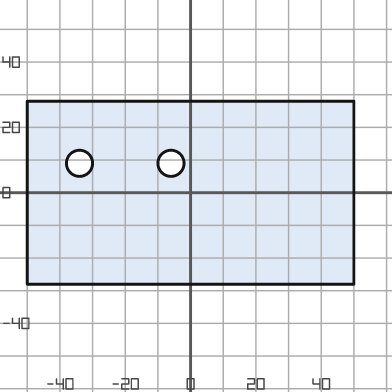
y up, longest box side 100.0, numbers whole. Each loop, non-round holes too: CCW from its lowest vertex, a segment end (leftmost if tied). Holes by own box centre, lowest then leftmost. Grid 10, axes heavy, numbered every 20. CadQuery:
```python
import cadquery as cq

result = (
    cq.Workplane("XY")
    .moveTo(-50.0, -28.0)
    .lineTo(50.0, -28.0)
    .lineTo(50.0, 28.0)
    .lineTo(-50.0, 28.0)
    .close()
    .moveTo(-34.0, 9.0)
    .circle(4.0)
    .moveTo(-6.0, 9.0)
    .circle(4.0)
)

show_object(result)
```